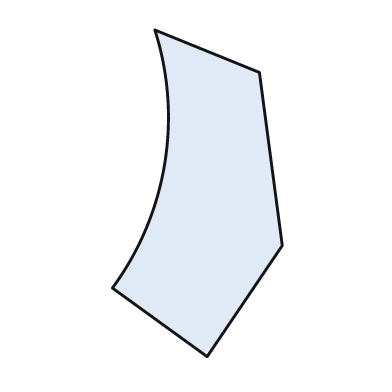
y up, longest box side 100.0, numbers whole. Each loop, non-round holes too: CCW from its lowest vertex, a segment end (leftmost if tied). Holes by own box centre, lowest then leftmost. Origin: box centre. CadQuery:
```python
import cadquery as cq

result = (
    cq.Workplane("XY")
    .moveTo(3.0, -50.0)
    .lineTo(26.0, -16.0)
    .lineTo(19.0, 37.0)
    .lineTo(-13.0, 50.0)
    .threePointArc((-10.0, 9.0), (-26.0, -29.0))
    .close()
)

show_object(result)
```